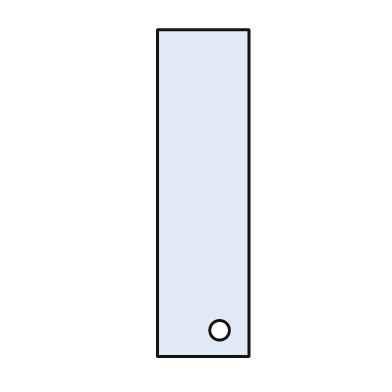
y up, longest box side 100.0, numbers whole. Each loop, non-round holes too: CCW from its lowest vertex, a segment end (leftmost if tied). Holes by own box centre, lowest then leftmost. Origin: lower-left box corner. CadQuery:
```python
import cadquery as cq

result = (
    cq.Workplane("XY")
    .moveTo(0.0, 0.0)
    .lineTo(28.0, 0.0)
    .lineTo(28.0, 100.0)
    .lineTo(0.0, 100.0)
    .close()
    .moveTo(19.0, 8.0)
    .circle(3.0)
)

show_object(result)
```